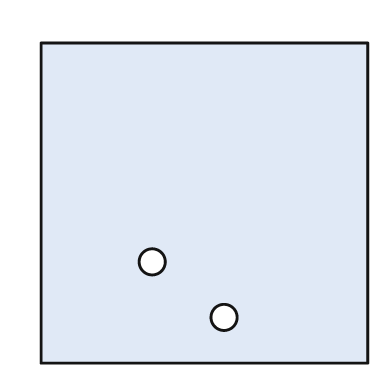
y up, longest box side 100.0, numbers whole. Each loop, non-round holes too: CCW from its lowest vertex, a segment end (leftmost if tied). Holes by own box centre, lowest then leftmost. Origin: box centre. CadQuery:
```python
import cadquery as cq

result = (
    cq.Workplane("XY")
    .moveTo(-50.0, -49.0)
    .lineTo(50.0, -49.0)
    .lineTo(50.0, 49.0)
    .lineTo(-50.0, 49.0)
    .close()
    .moveTo(6.0, -35.0)
    .circle(4.0)
    .moveTo(-16.0, -18.0)
    .circle(4.0)
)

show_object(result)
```